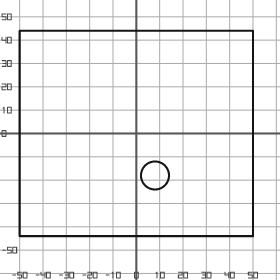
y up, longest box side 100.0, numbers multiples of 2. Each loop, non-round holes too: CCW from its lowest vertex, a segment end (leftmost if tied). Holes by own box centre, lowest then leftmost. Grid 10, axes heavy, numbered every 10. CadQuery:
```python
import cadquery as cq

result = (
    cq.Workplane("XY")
    .moveTo(-50.0, -44.0)
    .lineTo(50.0, -44.0)
    .lineTo(50.0, 44.0)
    .lineTo(-50.0, 44.0)
    .close()
    .moveTo(8.0, -18.0)
    .circle(6.0)
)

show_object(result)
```